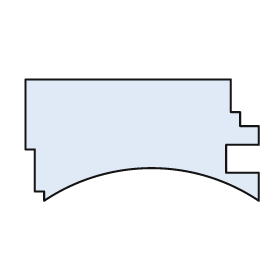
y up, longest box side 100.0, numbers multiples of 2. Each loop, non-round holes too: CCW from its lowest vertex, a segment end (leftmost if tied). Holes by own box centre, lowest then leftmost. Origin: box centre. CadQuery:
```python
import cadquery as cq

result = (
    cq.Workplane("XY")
    .moveTo(-42.0, -26.0)
    .threePointArc((4.0, -12.0), (50.0, -26.0))
    .lineTo(50.0, -14.0)
    .lineTo(36.0, -14.0)
    .lineTo(36.0, -2.0)
    .lineTo(50.0, -2.0)
    .lineTo(50.0, 6.0)
    .lineTo(42.0, 6.0)
    .lineTo(42.0, 12.0)
    .lineTo(38.0, 12.0)
    .lineTo(38.0, 26.0)
    .lineTo(-50.0, 26.0)
    .lineTo(-50.0, -4.0)
    .lineTo(-46.0, -4.0)
    .lineTo(-46.0, -22.0)
    .lineTo(-42.0, -22.0)
    .close()
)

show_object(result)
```